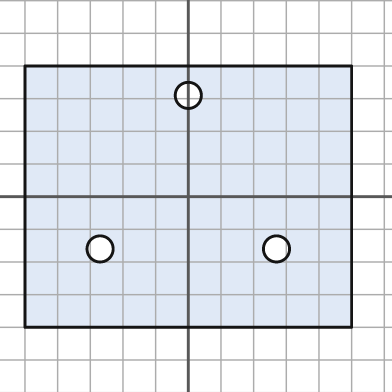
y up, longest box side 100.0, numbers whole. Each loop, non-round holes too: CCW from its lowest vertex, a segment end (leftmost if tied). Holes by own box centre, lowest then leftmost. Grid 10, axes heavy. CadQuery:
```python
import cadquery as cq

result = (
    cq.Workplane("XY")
    .moveTo(-50.0, -40.0)
    .lineTo(50.0, -40.0)
    .lineTo(50.0, 40.0)
    .lineTo(-50.0, 40.0)
    .close()
    .moveTo(-27.0, -16.0)
    .circle(4.0)
    .moveTo(27.0, -16.0)
    .circle(4.0)
    .moveTo(0.0, 31.0)
    .circle(4.0)
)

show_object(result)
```